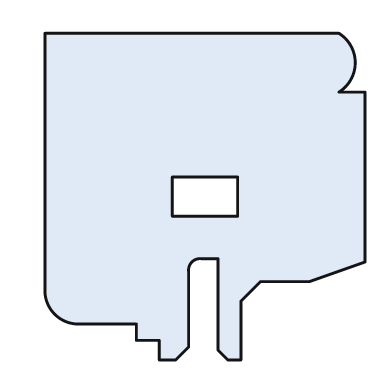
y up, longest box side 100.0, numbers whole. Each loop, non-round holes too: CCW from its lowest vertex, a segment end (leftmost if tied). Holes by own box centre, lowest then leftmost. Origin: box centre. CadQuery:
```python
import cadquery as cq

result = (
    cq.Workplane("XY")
    .moveTo(-14.0, -50.0)
    .lineTo(-9.0, -50.0)
    .lineTo(-5.0, -46.0)
    .lineTo(-5.0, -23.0)
    .threePointArc((-4.0, -20.0), (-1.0, -19.0))
    .lineTo(4.0, -19.0)
    .lineTo(4.0, -47.0)
    .lineTo(7.0, -50.0)
    .lineTo(11.0, -50.0)
    .lineTo(11.0, -32.0)
    .lineTo(17.0, -26.0)
    .lineTo(32.0, -26.0)
    .lineTo(49.0, -20.0)
    .lineTo(49.0, 32.0)
    .lineTo(41.0, 32.0)
    .threePointArc((46.0, 41.0), (41.0, 50.0))
    .lineTo(-49.0, 50.0)
    .lineTo(-49.0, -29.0)
    .threePointArc((-46.0, -36.0), (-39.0, -39.0))
    .lineTo(-21.0, -39.0)
    .lineTo(-21.0, -44.0)
    .lineTo(-14.0, -44.0)
    .close()
    .moveTo(-10.0, -6.0)
    .lineTo(10.0, -6.0)
    .lineTo(10.0, 6.0)
    .lineTo(-10.0, 6.0)
    .close()
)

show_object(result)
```